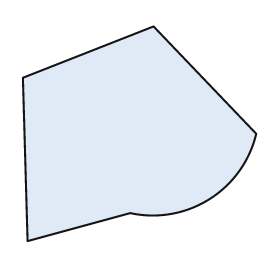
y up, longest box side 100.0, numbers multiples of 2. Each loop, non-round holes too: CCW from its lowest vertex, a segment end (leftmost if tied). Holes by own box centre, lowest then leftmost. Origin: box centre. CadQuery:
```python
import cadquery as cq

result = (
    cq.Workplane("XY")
    .moveTo(-48.0, -46.0)
    .lineTo(-4.0, -34.0)
    .threePointArc((30.0, -28.0), (50.0, 0.0))
    .lineTo(6.0, 46.0)
    .lineTo(-50.0, 24.0)
    .close()
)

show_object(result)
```